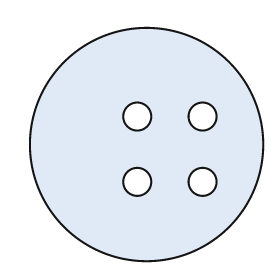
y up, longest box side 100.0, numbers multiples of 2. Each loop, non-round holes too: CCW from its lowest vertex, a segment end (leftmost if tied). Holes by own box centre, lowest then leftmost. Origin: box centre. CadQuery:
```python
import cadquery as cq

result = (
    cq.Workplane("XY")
    .moveTo(0.0, 0.0)
    .circle(50.0)
    .moveTo(-4.0, -16.0)
    .circle(6.0)
    .moveTo(24.0, -16.0)
    .circle(6.0)
    .moveTo(-4.0, 12.0)
    .circle(6.0)
    .moveTo(24.0, 12.0)
    .circle(6.0)
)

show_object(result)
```